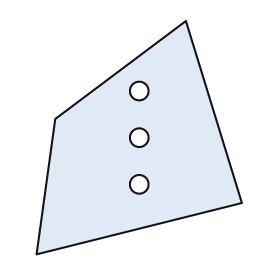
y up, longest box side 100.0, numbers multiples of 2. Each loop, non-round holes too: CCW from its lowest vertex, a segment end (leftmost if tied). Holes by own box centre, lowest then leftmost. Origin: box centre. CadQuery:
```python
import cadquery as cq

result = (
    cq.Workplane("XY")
    .moveTo(-44.0, -50.0)
    .lineTo(44.0, -28.0)
    .lineTo(20.0, 50.0)
    .lineTo(-36.0, 8.0)
    .close()
    .moveTo(0.0, -20.0)
    .circle(4.0)
    .moveTo(0.0, 0.0)
    .circle(4.0)
    .moveTo(0.0, 20.0)
    .circle(4.0)
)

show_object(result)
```